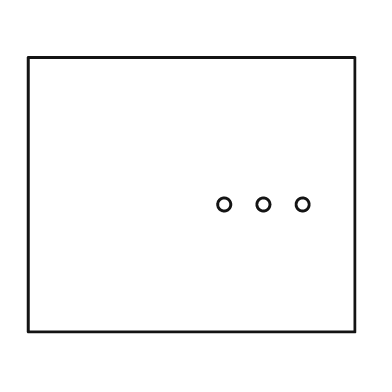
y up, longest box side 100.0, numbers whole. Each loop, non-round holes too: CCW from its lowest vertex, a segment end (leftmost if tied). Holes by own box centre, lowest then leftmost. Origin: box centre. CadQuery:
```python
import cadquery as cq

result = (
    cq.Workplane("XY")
    .moveTo(-50.0, -42.0)
    .lineTo(50.0, -42.0)
    .lineTo(50.0, 42.0)
    .lineTo(-50.0, 42.0)
    .close()
    .moveTo(10.0, -3.0)
    .circle(2.0)
    .moveTo(22.0, -3.0)
    .circle(2.0)
    .moveTo(34.0, -3.0)
    .circle(2.0)
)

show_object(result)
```